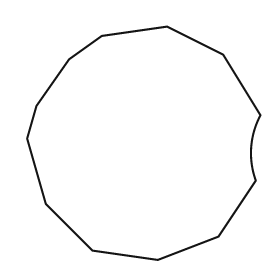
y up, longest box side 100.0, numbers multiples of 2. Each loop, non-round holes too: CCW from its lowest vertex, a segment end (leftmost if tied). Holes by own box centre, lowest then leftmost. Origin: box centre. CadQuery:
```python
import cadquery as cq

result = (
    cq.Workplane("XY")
    .moveTo(6.0, -50.0)
    .lineTo(32.0, -40.0)
    .lineTo(48.0, -16.0)
    .threePointArc((46.0, -2.0), (50.0, 12.0))
    .lineTo(34.0, 38.0)
    .lineTo(10.0, 50.0)
    .lineTo(-18.0, 46.0)
    .lineTo(-32.0, 36.0)
    .lineTo(-46.0, 16.0)
    .lineTo(-50.0, 2.0)
    .lineTo(-42.0, -26.0)
    .lineTo(-22.0, -46.0)
    .close()
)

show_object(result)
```